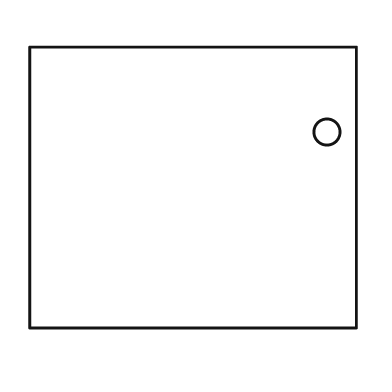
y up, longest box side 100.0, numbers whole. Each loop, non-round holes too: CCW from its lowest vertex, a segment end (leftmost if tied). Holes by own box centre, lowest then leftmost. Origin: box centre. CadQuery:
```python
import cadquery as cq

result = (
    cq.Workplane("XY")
    .moveTo(-50.0, -43.0)
    .lineTo(50.0, -43.0)
    .lineTo(50.0, 43.0)
    .lineTo(-50.0, 43.0)
    .close()
    .moveTo(41.0, 17.0)
    .circle(4.0)
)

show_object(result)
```